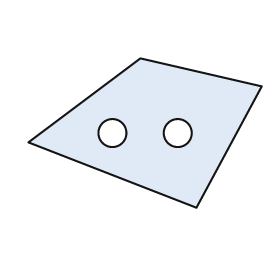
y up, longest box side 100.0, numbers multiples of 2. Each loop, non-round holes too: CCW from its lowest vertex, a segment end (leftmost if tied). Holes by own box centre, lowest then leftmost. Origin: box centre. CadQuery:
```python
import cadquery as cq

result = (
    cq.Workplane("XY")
    .moveTo(22.0, -32.0)
    .lineTo(50.0, 20.0)
    .lineTo(-2.0, 32.0)
    .lineTo(-50.0, -4.0)
    .close()
    .moveTo(-14.0, 0.0)
    .circle(6.0)
    .moveTo(14.0, 0.0)
    .circle(6.0)
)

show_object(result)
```